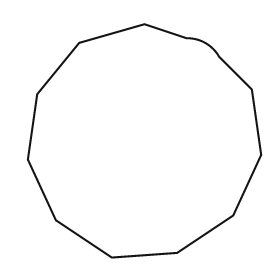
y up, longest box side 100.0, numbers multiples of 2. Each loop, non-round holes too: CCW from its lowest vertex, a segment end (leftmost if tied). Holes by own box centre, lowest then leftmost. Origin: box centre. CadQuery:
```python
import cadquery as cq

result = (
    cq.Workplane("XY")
    .moveTo(-14.0, -50.0)
    .lineTo(14.0, -48.0)
    .lineTo(38.0, -32.0)
    .lineTo(50.0, -6.0)
    .lineTo(46.0, 22.0)
    .lineTo(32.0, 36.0)
    .threePointArc((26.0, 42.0), (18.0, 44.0))
    .lineTo(0.0, 50.0)
    .lineTo(-28.0, 42.0)
    .lineTo(-46.0, 20.0)
    .lineTo(-50.0, -8.0)
    .lineTo(-38.0, -34.0)
    .close()
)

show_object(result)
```